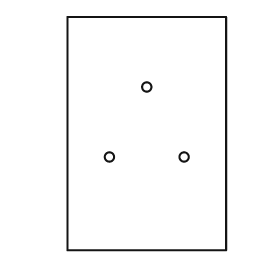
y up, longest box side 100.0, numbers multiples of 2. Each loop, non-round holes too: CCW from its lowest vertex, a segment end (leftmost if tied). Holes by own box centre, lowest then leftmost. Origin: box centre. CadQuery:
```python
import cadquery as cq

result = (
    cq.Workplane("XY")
    .moveTo(-34.0, -50.0)
    .lineTo(34.0, -50.0)
    .lineTo(34.0, 50.0)
    .lineTo(-34.0, 50.0)
    .close()
    .moveTo(-16.0, -10.0)
    .circle(2.0)
    .moveTo(16.0, -10.0)
    .circle(2.0)
    .moveTo(0.0, 20.0)
    .circle(2.0)
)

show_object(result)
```